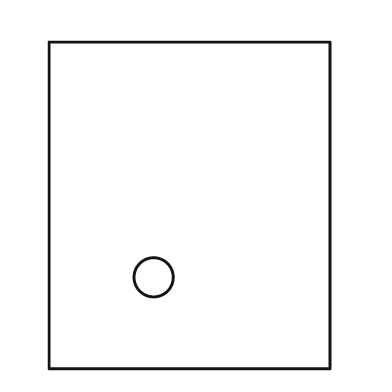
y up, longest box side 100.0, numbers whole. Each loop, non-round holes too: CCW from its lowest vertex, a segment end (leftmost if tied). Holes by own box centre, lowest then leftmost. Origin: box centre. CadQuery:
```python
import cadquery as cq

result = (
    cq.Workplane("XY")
    .moveTo(-43.0, -50.0)
    .lineTo(43.0, -50.0)
    .lineTo(43.0, 50.0)
    .lineTo(-43.0, 50.0)
    .close()
    .moveTo(-11.0, -22.0)
    .circle(6.0)
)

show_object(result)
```